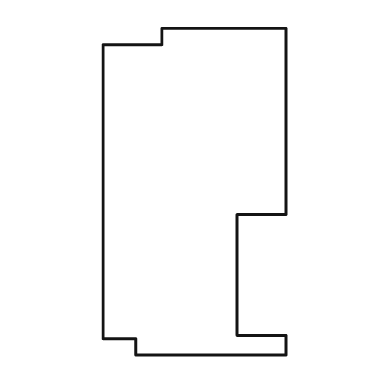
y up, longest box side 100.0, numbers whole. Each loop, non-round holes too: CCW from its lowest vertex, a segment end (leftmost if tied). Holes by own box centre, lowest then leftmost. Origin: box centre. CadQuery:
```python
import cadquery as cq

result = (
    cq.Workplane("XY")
    .moveTo(-18.0, -50.0)
    .lineTo(28.0, -50.0)
    .lineTo(28.0, -44.0)
    .lineTo(13.0, -44.0)
    .lineTo(13.0, -7.0)
    .lineTo(28.0, -7.0)
    .lineTo(28.0, 50.0)
    .lineTo(-10.0, 50.0)
    .lineTo(-10.0, 45.0)
    .lineTo(-28.0, 45.0)
    .lineTo(-28.0, -45.0)
    .lineTo(-18.0, -45.0)
    .close()
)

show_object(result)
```